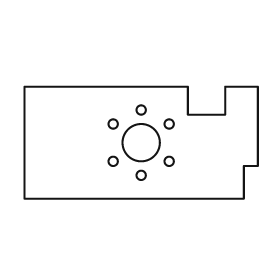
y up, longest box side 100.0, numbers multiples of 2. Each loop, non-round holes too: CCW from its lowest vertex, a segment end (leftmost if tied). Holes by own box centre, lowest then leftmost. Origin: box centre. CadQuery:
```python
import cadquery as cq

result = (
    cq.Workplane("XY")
    .moveTo(-50.0, -24.0)
    .lineTo(44.0, -24.0)
    .lineTo(44.0, -10.0)
    .lineTo(50.0, -10.0)
    .lineTo(50.0, 24.0)
    .lineTo(36.0, 24.0)
    .lineTo(36.0, 12.0)
    .lineTo(20.0, 12.0)
    .lineTo(20.0, 24.0)
    .lineTo(-50.0, 24.0)
    .close()
    .moveTo(0.0, -14.0)
    .circle(2.0)
    .moveTo(-12.0, -8.0)
    .circle(2.0)
    .moveTo(12.0, -8.0)
    .circle(2.0)
    .moveTo(0.0, 0.0)
    .circle(8.0)
    .moveTo(-12.0, 8.0)
    .circle(2.0)
    .moveTo(12.0, 8.0)
    .circle(2.0)
    .moveTo(0.0, 14.0)
    .circle(2.0)
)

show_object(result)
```